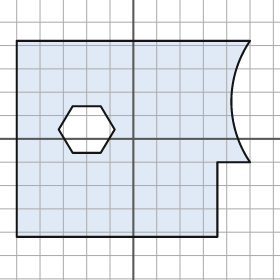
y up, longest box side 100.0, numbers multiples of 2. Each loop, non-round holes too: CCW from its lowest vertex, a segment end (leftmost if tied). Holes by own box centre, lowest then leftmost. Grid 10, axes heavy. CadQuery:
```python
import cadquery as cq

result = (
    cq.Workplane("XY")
    .moveTo(-50.0, -42.0)
    .lineTo(36.0, -42.0)
    .lineTo(36.0, -10.0)
    .lineTo(50.0, -10.0)
    .threePointArc((42.0, 16.0), (50.0, 42.0))
    .lineTo(-50.0, 42.0)
    .close()
    .moveTo(-26.0, -6.0)
    .lineTo(-14.0, -6.0)
    .lineTo(-8.0, 4.0)
    .lineTo(-14.0, 14.0)
    .lineTo(-26.0, 14.0)
    .lineTo(-32.0, 4.0)
    .close()
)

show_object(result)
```